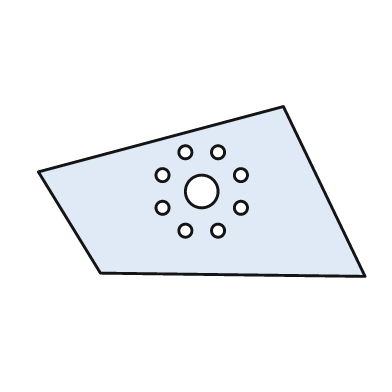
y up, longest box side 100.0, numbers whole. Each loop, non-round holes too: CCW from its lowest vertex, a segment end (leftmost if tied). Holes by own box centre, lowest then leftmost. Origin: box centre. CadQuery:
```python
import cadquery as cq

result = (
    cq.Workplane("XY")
    .moveTo(50.0, -26.0)
    .lineTo(25.0, 26.0)
    .lineTo(-50.0, 6.0)
    .lineTo(-31.0, -25.0)
    .close()
    .moveTo(-5.0, -12.0)
    .circle(2.0)
    .moveTo(5.0, -12.0)
    .circle(2.0)
    .moveTo(-12.0, -5.0)
    .circle(2.0)
    .moveTo(12.0, -5.0)
    .circle(2.0)
    .moveTo(0.0, 0.0)
    .circle(5.0)
    .moveTo(-12.0, 5.0)
    .circle(2.0)
    .moveTo(12.0, 5.0)
    .circle(2.0)
    .moveTo(-5.0, 12.0)
    .circle(2.0)
    .moveTo(5.0, 12.0)
    .circle(2.0)
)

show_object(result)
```